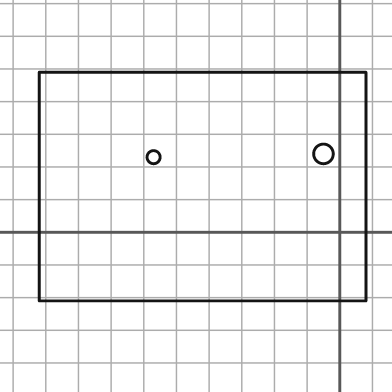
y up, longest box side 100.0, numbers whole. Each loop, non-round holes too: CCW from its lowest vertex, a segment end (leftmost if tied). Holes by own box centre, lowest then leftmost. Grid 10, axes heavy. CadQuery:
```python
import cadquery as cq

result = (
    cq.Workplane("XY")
    .moveTo(-92.0, -21.0)
    .lineTo(8.0, -21.0)
    .lineTo(8.0, 49.0)
    .lineTo(-92.0, 49.0)
    .close()
    .moveTo(-57.0, 23.0)
    .circle(2.0)
    .moveTo(-5.0, 24.0)
    .circle(3.0)
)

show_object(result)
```